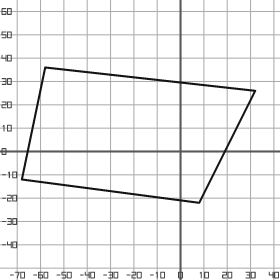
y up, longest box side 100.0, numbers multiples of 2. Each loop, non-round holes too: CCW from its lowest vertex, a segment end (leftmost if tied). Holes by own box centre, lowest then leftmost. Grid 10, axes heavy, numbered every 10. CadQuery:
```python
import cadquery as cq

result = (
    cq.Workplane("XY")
    .moveTo(8.0, -22.0)
    .lineTo(32.0, 26.0)
    .lineTo(-58.0, 36.0)
    .lineTo(-68.0, -12.0)
    .close()
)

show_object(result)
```